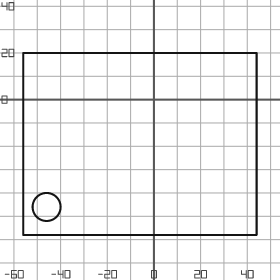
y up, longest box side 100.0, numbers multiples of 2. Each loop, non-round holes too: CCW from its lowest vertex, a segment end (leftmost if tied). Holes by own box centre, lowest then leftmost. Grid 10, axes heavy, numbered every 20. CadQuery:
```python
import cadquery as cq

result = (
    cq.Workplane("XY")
    .moveTo(-56.0, -58.0)
    .lineTo(44.0, -58.0)
    .lineTo(44.0, 20.0)
    .lineTo(-56.0, 20.0)
    .close()
    .moveTo(-46.0, -46.0)
    .circle(6.0)
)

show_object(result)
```